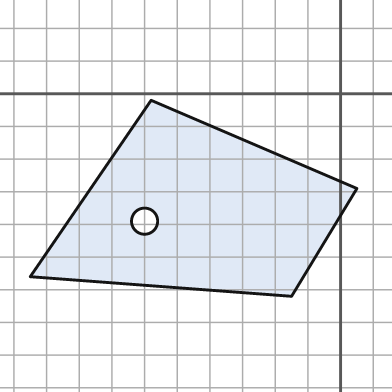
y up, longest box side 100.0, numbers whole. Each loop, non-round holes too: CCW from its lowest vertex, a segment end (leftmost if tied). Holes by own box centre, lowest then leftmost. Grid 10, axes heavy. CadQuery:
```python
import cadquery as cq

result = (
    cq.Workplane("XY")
    .moveTo(-15.0, -62.0)
    .lineTo(5.0, -29.0)
    .lineTo(-58.0, -2.0)
    .lineTo(-95.0, -56.0)
    .close()
    .moveTo(-60.0, -39.0)
    .circle(4.0)
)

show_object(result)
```